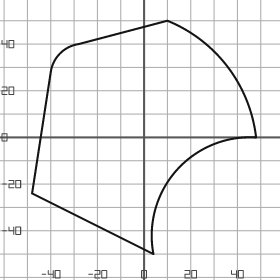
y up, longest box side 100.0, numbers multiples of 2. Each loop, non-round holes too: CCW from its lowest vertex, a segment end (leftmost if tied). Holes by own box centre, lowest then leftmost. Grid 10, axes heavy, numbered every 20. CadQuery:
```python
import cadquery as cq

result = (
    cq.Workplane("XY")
    .moveTo(4.0, -50.0)
    .threePointArc((14.0, -14.0), (48.0, 0.0))
    .threePointArc((36.0, 30.0), (10.0, 50.0))
    .lineTo(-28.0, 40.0)
    .threePointArc((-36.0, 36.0), (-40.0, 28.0))
    .lineTo(-48.0, -24.0)
    .close()
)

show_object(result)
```